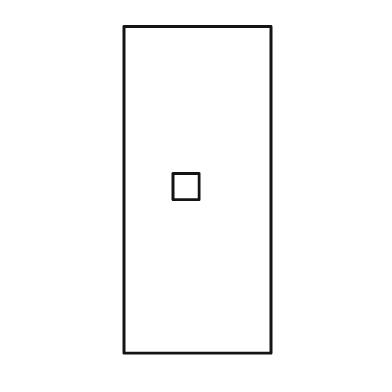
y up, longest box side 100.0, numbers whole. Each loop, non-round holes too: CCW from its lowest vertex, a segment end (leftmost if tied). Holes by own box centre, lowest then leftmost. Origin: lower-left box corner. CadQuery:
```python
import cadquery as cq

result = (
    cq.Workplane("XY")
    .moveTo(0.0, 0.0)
    .lineTo(45.0, 0.0)
    .lineTo(45.0, 100.0)
    .lineTo(0.0, 100.0)
    .close()
    .moveTo(15.0, 47.0)
    .lineTo(23.0, 47.0)
    .lineTo(23.0, 55.0)
    .lineTo(15.0, 55.0)
    .close()
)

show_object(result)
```